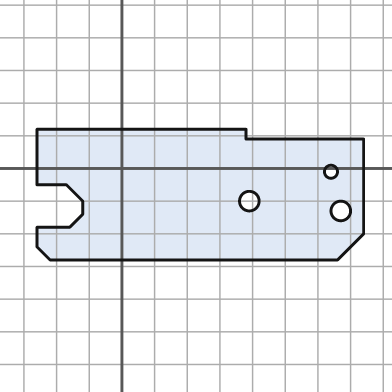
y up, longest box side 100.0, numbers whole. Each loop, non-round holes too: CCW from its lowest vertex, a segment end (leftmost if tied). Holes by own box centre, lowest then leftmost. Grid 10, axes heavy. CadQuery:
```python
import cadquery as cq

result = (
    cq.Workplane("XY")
    .moveTo(-22.0, -28.0)
    .lineTo(66.0, -28.0)
    .lineTo(74.0, -20.0)
    .lineTo(74.0, 9.0)
    .lineTo(38.0, 9.0)
    .lineTo(38.0, 12.0)
    .lineTo(-26.0, 12.0)
    .lineTo(-26.0, -5.0)
    .lineTo(-17.0, -5.0)
    .lineTo(-12.0, -10.0)
    .lineTo(-12.0, -14.0)
    .lineTo(-16.0, -18.0)
    .lineTo(-26.0, -18.0)
    .lineTo(-26.0, -24.0)
    .close()
    .moveTo(67.0, -13.0)
    .circle(3.0)
    .moveTo(39.0, -10.0)
    .circle(3.0)
    .moveTo(64.0, -1.0)
    .circle(2.0)
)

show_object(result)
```